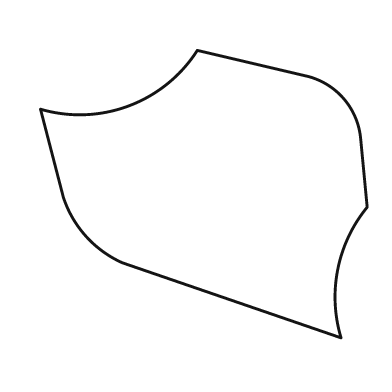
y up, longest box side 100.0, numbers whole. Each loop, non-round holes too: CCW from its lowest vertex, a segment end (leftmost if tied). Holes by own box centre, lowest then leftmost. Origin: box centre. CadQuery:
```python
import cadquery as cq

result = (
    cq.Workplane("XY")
    .moveTo(42.0, -44.0)
    .threePointArc((41.0, -23.0), (50.0, -4.0))
    .lineTo(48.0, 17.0)
    .threePointArc((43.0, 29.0), (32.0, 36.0))
    .lineTo(-2.0, 44.0)
    .threePointArc((-23.0, 27.0), (-50.0, 26.0))
    .lineTo(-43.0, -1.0)
    .threePointArc((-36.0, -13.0), (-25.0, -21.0))
    .close()
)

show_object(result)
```